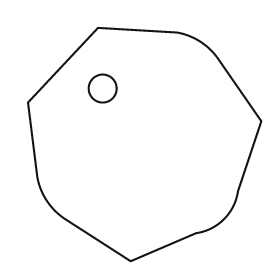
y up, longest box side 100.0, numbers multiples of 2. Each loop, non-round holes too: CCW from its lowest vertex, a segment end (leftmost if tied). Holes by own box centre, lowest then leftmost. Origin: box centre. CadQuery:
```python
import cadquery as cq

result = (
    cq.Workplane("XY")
    .moveTo(-6.0, -50.0)
    .lineTo(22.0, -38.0)
    .threePointArc((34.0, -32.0), (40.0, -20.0))
    .lineTo(50.0, 10.0)
    .lineTo(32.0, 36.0)
    .threePointArc((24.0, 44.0), (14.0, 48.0))
    .lineTo(-20.0, 50.0)
    .lineTo(-50.0, 18.0)
    .lineTo(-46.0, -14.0)
    .threePointArc((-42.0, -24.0), (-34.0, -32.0))
    .close()
    .moveTo(-18.0, 24.0)
    .circle(6.0)
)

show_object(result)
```